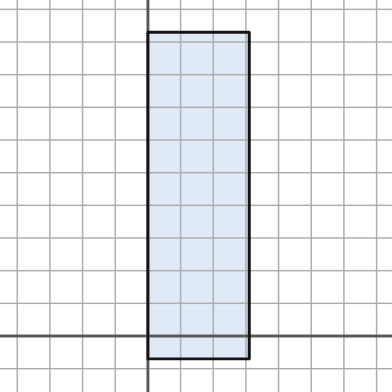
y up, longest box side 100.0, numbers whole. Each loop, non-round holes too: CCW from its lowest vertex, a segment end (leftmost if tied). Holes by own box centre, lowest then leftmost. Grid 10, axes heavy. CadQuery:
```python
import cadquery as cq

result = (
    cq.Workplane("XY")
    .moveTo(0.0, -7.0)
    .lineTo(31.0, -7.0)
    .lineTo(31.0, 93.0)
    .lineTo(0.0, 93.0)
    .close()
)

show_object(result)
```